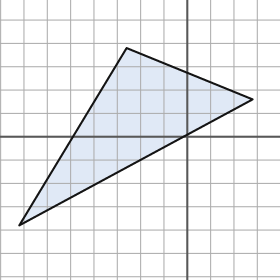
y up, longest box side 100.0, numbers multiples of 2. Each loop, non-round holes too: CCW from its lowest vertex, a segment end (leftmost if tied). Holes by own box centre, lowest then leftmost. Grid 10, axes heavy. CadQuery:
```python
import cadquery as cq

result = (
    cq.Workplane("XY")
    .moveTo(-72.0, -38.0)
    .lineTo(28.0, 16.0)
    .lineTo(-26.0, 38.0)
    .close()
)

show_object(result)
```